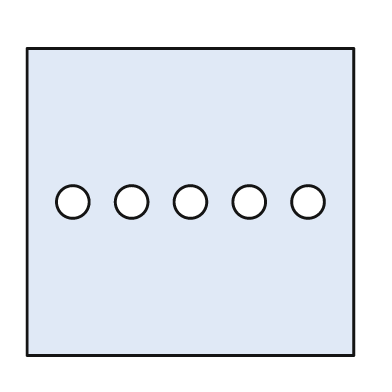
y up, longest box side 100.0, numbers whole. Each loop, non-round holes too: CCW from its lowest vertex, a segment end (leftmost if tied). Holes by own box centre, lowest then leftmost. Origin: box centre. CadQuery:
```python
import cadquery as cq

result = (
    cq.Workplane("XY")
    .moveTo(-50.0, -47.0)
    .lineTo(50.0, -47.0)
    .lineTo(50.0, 47.0)
    .lineTo(-50.0, 47.0)
    .close()
    .moveTo(-36.0, 0.0)
    .circle(5.0)
    .moveTo(-18.0, 0.0)
    .circle(5.0)
    .moveTo(0.0, 0.0)
    .circle(5.0)
    .moveTo(18.0, 0.0)
    .circle(5.0)
    .moveTo(36.0, 0.0)
    .circle(5.0)
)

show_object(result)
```